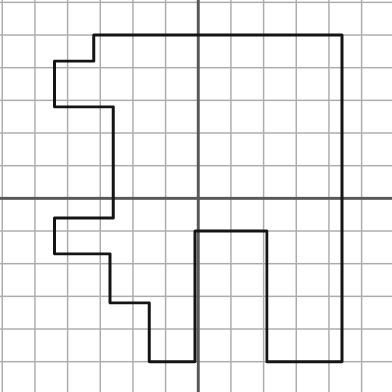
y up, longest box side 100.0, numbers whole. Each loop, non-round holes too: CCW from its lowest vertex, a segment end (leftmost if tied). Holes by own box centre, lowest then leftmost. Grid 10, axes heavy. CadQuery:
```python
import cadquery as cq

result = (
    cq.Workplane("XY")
    .moveTo(-15.0, -50.0)
    .lineTo(-1.0, -50.0)
    .lineTo(-1.0, -10.0)
    .lineTo(21.0, -10.0)
    .lineTo(21.0, -50.0)
    .lineTo(44.0, -50.0)
    .lineTo(44.0, 50.0)
    .lineTo(-32.0, 50.0)
    .lineTo(-32.0, 42.0)
    .lineTo(-44.0, 42.0)
    .lineTo(-44.0, 28.0)
    .lineTo(-26.0, 28.0)
    .lineTo(-26.0, -6.0)
    .lineTo(-44.0, -6.0)
    .lineTo(-44.0, -17.0)
    .lineTo(-27.0, -17.0)
    .lineTo(-27.0, -32.0)
    .lineTo(-15.0, -32.0)
    .close()
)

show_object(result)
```